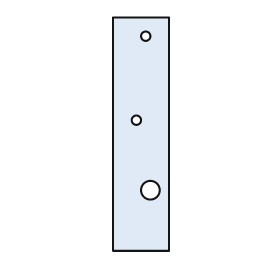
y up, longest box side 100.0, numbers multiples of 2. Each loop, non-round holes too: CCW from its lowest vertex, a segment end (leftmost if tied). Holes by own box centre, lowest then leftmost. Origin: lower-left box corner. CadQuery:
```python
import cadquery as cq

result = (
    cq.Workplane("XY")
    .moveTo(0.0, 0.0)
    .lineTo(24.0, 0.0)
    .lineTo(24.0, 100.0)
    .lineTo(0.0, 100.0)
    .close()
    .moveTo(16.0, 26.0)
    .circle(4.0)
    .moveTo(10.0, 56.0)
    .circle(2.0)
    .moveTo(14.0, 92.0)
    .circle(2.0)
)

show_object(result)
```